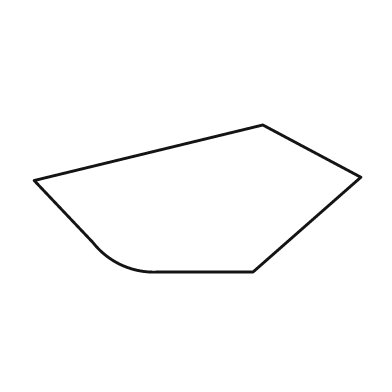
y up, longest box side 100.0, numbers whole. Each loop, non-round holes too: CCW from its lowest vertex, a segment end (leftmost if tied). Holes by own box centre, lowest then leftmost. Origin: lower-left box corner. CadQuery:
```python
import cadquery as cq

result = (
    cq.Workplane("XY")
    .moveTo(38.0, 0.0)
    .lineTo(67.0, 0.0)
    .lineTo(100.0, 29.0)
    .lineTo(70.0, 45.0)
    .lineTo(0.0, 28.0)
    .lineTo(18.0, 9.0)
    .threePointArc((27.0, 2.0), (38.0, 0.0))
    .close()
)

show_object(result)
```